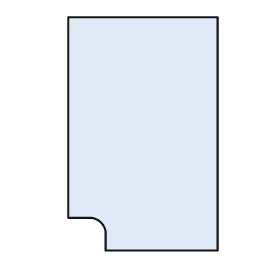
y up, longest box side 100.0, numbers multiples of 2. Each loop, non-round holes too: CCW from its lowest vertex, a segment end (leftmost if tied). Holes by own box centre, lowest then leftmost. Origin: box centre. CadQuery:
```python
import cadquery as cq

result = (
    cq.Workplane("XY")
    .moveTo(-16.0, -50.0)
    .lineTo(32.0, -50.0)
    .lineTo(32.0, 50.0)
    .lineTo(-32.0, 50.0)
    .lineTo(-32.0, -36.0)
    .lineTo(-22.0, -36.0)
    .threePointArc((-18.0, -38.0), (-16.0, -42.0))
    .close()
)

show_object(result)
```